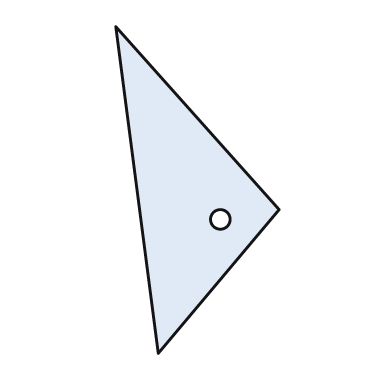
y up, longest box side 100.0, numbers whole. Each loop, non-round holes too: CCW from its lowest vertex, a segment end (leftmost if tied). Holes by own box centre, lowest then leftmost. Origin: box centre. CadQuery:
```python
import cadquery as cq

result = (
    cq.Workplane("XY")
    .moveTo(-12.0, -50.0)
    .lineTo(25.0, -6.0)
    .lineTo(-25.0, 50.0)
    .close()
    .moveTo(7.0, -9.0)
    .circle(3.0)
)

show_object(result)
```